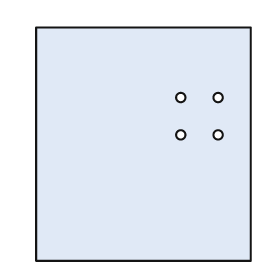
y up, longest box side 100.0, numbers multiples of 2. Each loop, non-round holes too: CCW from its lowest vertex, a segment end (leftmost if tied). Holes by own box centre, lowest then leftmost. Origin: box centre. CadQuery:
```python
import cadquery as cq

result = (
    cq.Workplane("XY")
    .moveTo(-46.0, -50.0)
    .lineTo(46.0, -50.0)
    .lineTo(46.0, 50.0)
    .lineTo(-46.0, 50.0)
    .close()
    .moveTo(16.0, 4.0)
    .circle(2.0)
    .moveTo(32.0, 4.0)
    .circle(2.0)
    .moveTo(16.0, 20.0)
    .circle(2.0)
    .moveTo(32.0, 20.0)
    .circle(2.0)
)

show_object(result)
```